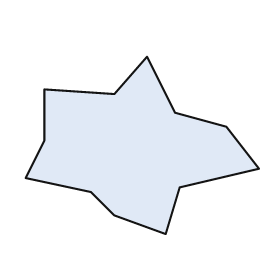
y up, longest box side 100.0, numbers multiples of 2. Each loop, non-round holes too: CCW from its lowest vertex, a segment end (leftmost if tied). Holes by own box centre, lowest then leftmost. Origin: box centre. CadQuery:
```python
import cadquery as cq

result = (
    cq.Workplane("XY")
    .moveTo(10.0, -38.0)
    .lineTo(16.0, -18.0)
    .lineTo(50.0, -10.0)
    .lineTo(36.0, 8.0)
    .lineTo(14.0, 14.0)
    .lineTo(2.0, 38.0)
    .lineTo(-12.0, 22.0)
    .lineTo(-42.0, 24.0)
    .lineTo(-42.0, 2.0)
    .lineTo(-50.0, -14.0)
    .lineTo(-22.0, -20.0)
    .lineTo(-12.0, -30.0)
    .close()
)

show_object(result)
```